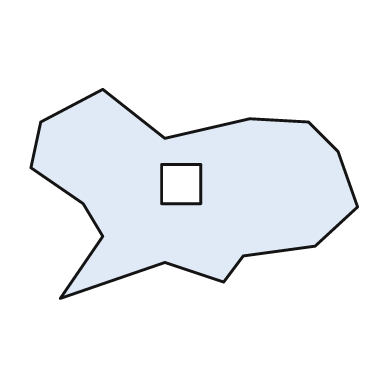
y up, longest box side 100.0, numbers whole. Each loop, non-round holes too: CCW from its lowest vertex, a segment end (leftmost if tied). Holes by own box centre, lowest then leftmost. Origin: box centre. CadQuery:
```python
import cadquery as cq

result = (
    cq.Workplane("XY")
    .moveTo(-41.0, -32.0)
    .lineTo(-9.0, -21.0)
    .lineTo(9.0, -27.0)
    .lineTo(15.0, -19.0)
    .lineTo(37.0, -16.0)
    .lineTo(50.0, -4.0)
    .lineTo(44.0, 13.0)
    .lineTo(35.0, 22.0)
    .lineTo(17.0, 23.0)
    .lineTo(-9.0, 17.0)
    .lineTo(-28.0, 32.0)
    .lineTo(-47.0, 22.0)
    .lineTo(-50.0, 8.0)
    .lineTo(-34.0, -3.0)
    .lineTo(-28.0, -13.0)
    .close()
    .moveTo(-10.0, -3.0)
    .lineTo(2.0, -3.0)
    .lineTo(2.0, 9.0)
    .lineTo(-10.0, 9.0)
    .close()
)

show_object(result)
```